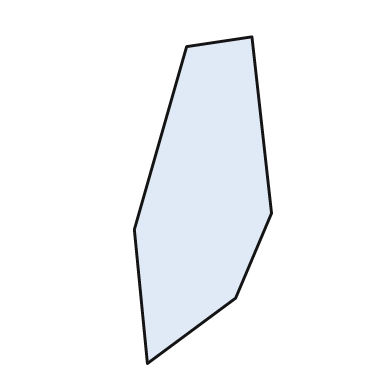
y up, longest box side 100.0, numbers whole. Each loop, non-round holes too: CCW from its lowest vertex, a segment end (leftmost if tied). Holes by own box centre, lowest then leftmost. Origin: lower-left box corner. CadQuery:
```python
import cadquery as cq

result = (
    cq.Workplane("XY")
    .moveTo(4.0, 0.0)
    .lineTo(31.0, 20.0)
    .lineTo(42.0, 46.0)
    .lineTo(36.0, 100.0)
    .lineTo(16.0, 97.0)
    .lineTo(0.0, 41.0)
    .close()
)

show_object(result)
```